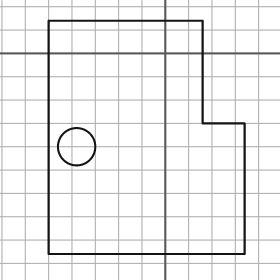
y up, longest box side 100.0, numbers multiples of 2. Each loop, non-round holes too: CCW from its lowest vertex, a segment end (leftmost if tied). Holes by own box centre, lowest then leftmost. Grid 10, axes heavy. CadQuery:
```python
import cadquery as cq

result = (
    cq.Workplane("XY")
    .moveTo(-50.0, -86.0)
    .lineTo(34.0, -86.0)
    .lineTo(34.0, -30.0)
    .lineTo(16.0, -30.0)
    .lineTo(16.0, 14.0)
    .lineTo(-50.0, 14.0)
    .close()
    .moveTo(-38.0, -40.0)
    .circle(8.0)
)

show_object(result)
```